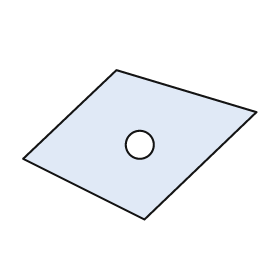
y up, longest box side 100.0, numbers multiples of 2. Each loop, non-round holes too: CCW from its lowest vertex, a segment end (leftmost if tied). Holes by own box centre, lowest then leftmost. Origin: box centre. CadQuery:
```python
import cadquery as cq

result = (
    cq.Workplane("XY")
    .moveTo(2.0, -32.0)
    .lineTo(50.0, 14.0)
    .lineTo(-10.0, 32.0)
    .lineTo(-50.0, -6.0)
    .close()
    .moveTo(0.0, 0.0)
    .circle(6.0)
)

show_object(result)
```